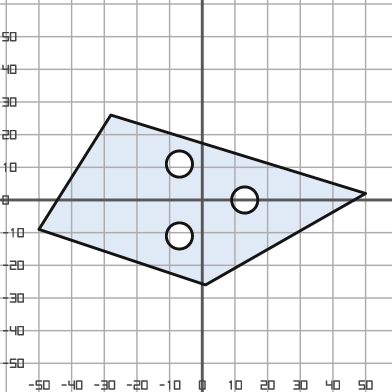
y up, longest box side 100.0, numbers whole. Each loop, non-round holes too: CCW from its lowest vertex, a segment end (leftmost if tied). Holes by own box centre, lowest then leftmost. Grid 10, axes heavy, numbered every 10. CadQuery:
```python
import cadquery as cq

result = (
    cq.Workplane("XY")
    .moveTo(1.0, -26.0)
    .lineTo(50.0, 2.0)
    .lineTo(-28.0, 26.0)
    .lineTo(-50.0, -9.0)
    .close()
    .moveTo(-7.0, -11.0)
    .circle(4.0)
    .moveTo(13.0, 0.0)
    .circle(4.0)
    .moveTo(-7.0, 11.0)
    .circle(4.0)
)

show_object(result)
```